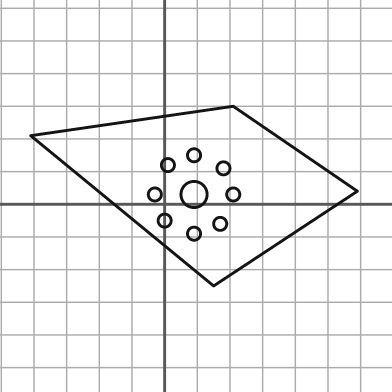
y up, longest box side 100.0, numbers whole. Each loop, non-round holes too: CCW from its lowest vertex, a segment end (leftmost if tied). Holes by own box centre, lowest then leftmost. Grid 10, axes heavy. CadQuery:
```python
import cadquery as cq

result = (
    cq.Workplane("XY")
    .moveTo(15.0, -25.0)
    .lineTo(59.0, 4.0)
    .lineTo(21.0, 30.0)
    .lineTo(-41.0, 21.0)
    .close()
    .moveTo(9.0, -9.0)
    .circle(2.0)
    .moveTo(17.0, -6.0)
    .circle(2.0)
    .moveTo(0.0, -5.0)
    .circle(2.0)
    .moveTo(-3.0, 3.0)
    .circle(2.0)
    .moveTo(9.0, 3.0)
    .circle(4.0)
    .moveTo(21.0, 3.0)
    .circle(2.0)
    .moveTo(18.0, 11.0)
    .circle(2.0)
    .moveTo(1.0, 12.0)
    .circle(2.0)
    .moveTo(9.0, 15.0)
    .circle(2.0)
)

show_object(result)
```